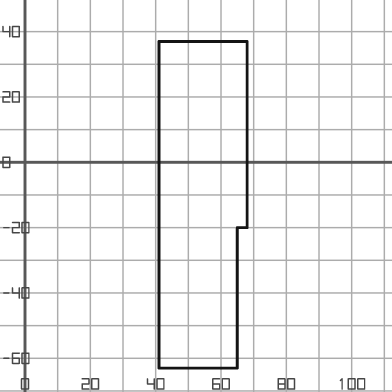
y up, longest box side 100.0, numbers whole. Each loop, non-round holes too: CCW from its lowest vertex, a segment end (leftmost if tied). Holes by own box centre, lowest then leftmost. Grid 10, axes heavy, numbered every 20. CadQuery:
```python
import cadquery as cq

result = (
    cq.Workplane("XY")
    .moveTo(41.0, -63.0)
    .lineTo(65.0, -63.0)
    .lineTo(65.0, -20.0)
    .lineTo(68.0, -20.0)
    .lineTo(68.0, 37.0)
    .lineTo(41.0, 37.0)
    .close()
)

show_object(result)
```